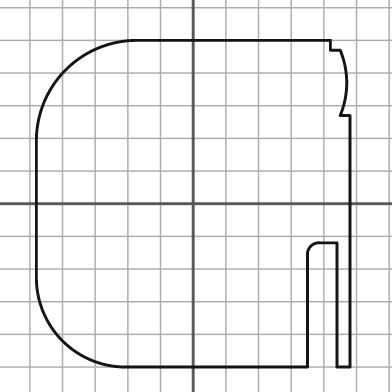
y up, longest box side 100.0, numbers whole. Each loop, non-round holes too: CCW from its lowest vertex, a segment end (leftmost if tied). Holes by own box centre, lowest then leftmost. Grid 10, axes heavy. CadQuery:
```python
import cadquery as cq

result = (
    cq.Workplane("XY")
    .moveTo(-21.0, -50.0)
    .lineTo(35.0, -50.0)
    .lineTo(35.0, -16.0)
    .threePointArc((36.0, -13.0), (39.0, -12.0))
    .lineTo(44.0, -12.0)
    .lineTo(44.0, -50.0)
    .lineTo(48.0, -50.0)
    .lineTo(48.0, 27.0)
    .lineTo(45.0, 27.0)
    .threePointArc((47.0, 37.0), (45.0, 47.0))
    .lineTo(42.0, 47.0)
    .lineTo(42.0, 50.0)
    .lineTo(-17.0, 50.0)
    .threePointArc((-39.0, 41.0), (-48.0, 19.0))
    .lineTo(-48.0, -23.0)
    .threePointArc((-40.0, -42.0), (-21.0, -50.0))
    .close()
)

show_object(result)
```